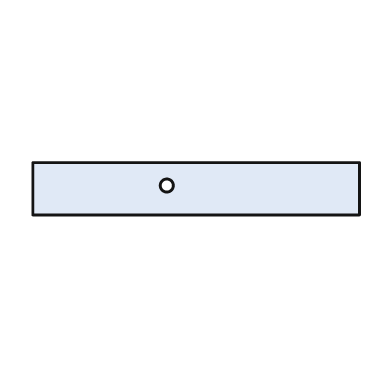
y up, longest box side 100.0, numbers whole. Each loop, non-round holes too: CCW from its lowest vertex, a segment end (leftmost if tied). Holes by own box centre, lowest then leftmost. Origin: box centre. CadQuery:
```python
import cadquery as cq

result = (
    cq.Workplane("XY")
    .moveTo(-50.0, -8.0)
    .lineTo(50.0, -8.0)
    .lineTo(50.0, 8.0)
    .lineTo(-50.0, 8.0)
    .close()
    .moveTo(-9.0, 1.0)
    .circle(2.0)
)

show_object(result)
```